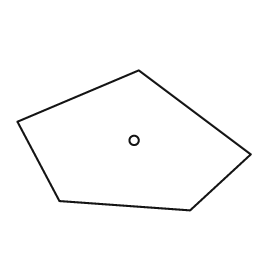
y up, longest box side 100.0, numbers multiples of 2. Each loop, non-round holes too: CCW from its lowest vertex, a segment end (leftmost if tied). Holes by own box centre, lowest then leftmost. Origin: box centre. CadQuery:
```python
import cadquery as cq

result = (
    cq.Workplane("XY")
    .moveTo(24.0, -30.0)
    .lineTo(50.0, -6.0)
    .lineTo(2.0, 30.0)
    .lineTo(-50.0, 8.0)
    .lineTo(-32.0, -26.0)
    .close()
    .moveTo(0.0, 0.0)
    .circle(2.0)
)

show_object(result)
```